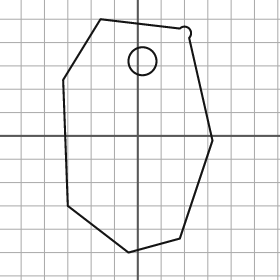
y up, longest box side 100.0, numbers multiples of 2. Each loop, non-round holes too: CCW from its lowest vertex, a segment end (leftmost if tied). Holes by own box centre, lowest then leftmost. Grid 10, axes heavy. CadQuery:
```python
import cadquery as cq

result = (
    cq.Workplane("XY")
    .moveTo(-4.0, -50.0)
    .lineTo(18.0, -44.0)
    .lineTo(32.0, -2.0)
    .lineTo(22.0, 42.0)
    .threePointArc((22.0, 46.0), (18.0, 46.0))
    .lineTo(-16.0, 50.0)
    .lineTo(-32.0, 24.0)
    .lineTo(-30.0, -30.0)
    .close()
    .moveTo(2.0, 32.0)
    .circle(6.0)
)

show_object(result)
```